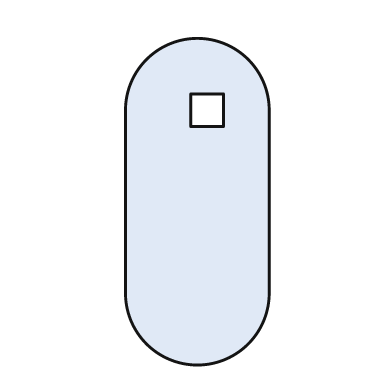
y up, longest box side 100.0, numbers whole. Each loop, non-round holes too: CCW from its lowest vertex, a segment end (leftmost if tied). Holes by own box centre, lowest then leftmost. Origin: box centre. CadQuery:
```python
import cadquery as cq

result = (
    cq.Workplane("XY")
    .moveTo(-22.0, -28.0)
    .threePointArc((0.0, -50.0), (22.0, -28.0))
    .lineTo(22.0, 28.0)
    .threePointArc((0.0, 50.0), (-22.0, 28.0))
    .close()
    .moveTo(-2.0, 23.0)
    .lineTo(8.0, 23.0)
    .lineTo(8.0, 33.0)
    .lineTo(-2.0, 33.0)
    .close()
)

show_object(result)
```